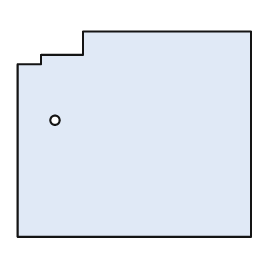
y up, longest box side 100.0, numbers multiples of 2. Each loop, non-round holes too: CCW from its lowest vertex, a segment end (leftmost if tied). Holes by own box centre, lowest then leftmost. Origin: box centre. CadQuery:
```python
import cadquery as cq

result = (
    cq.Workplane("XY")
    .moveTo(-50.0, -44.0)
    .lineTo(50.0, -44.0)
    .lineTo(50.0, 44.0)
    .lineTo(-22.0, 44.0)
    .lineTo(-22.0, 34.0)
    .lineTo(-40.0, 34.0)
    .lineTo(-40.0, 30.0)
    .lineTo(-50.0, 30.0)
    .close()
    .moveTo(-34.0, 6.0)
    .circle(2.0)
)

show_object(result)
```